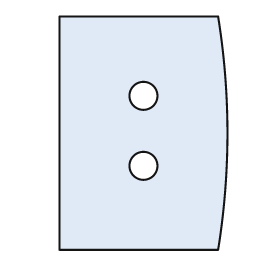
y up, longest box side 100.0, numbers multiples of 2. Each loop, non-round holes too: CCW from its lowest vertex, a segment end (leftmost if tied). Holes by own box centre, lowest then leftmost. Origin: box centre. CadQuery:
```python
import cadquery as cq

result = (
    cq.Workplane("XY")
    .moveTo(-36.0, -50.0)
    .lineTo(32.0, -50.0)
    .threePointArc((36.0, 0.0), (32.0, 50.0))
    .lineTo(-36.0, 50.0)
    .close()
    .moveTo(0.0, -14.0)
    .circle(6.0)
    .moveTo(0.0, 16.0)
    .circle(6.0)
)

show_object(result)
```